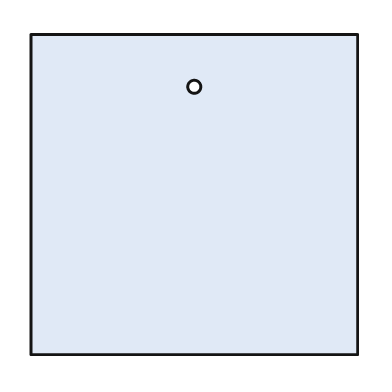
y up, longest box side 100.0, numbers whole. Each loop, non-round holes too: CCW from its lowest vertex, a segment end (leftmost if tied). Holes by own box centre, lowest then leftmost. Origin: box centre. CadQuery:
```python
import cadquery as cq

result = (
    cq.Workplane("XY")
    .moveTo(-50.0, -49.0)
    .lineTo(50.0, -49.0)
    .lineTo(50.0, 49.0)
    .lineTo(-50.0, 49.0)
    .close()
    .moveTo(0.0, 33.0)
    .circle(2.0)
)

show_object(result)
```